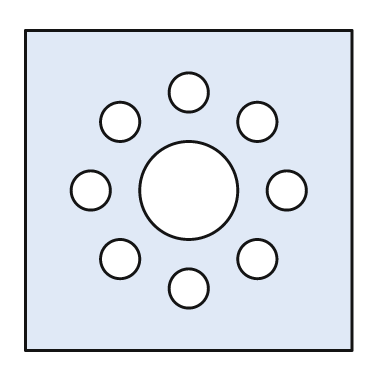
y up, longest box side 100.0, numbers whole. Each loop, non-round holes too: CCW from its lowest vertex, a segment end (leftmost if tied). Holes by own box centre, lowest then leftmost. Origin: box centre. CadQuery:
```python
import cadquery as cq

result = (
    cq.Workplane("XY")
    .moveTo(-50.0, -49.0)
    .lineTo(50.0, -49.0)
    .lineTo(50.0, 49.0)
    .lineTo(-50.0, 49.0)
    .close()
    .moveTo(0.0, -30.0)
    .circle(6.0)
    .moveTo(-21.0, -21.0)
    .circle(6.0)
    .moveTo(21.0, -21.0)
    .circle(6.0)
    .moveTo(-30.0, 0.0)
    .circle(6.0)
    .moveTo(0.0, 0.0)
    .circle(15.0)
    .moveTo(30.0, 0.0)
    .circle(6.0)
    .moveTo(-21.0, 21.0)
    .circle(6.0)
    .moveTo(21.0, 21.0)
    .circle(6.0)
    .moveTo(0.0, 30.0)
    .circle(6.0)
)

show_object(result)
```